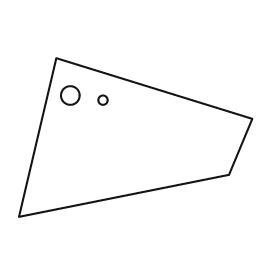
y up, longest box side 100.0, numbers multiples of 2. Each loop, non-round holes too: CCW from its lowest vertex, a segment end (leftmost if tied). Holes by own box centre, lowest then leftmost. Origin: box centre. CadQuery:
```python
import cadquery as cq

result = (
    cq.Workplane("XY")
    .moveTo(-50.0, -34.0)
    .lineTo(40.0, -16.0)
    .lineTo(50.0, 8.0)
    .lineTo(-34.0, 34.0)
    .close()
    .moveTo(-14.0, 16.0)
    .circle(2.0)
    .moveTo(-28.0, 18.0)
    .circle(4.0)
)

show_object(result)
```